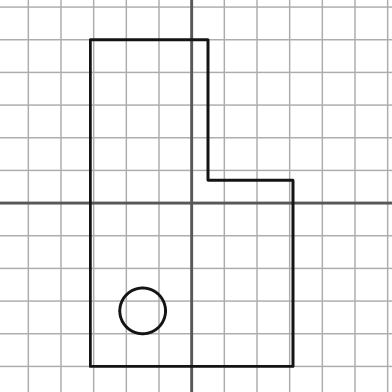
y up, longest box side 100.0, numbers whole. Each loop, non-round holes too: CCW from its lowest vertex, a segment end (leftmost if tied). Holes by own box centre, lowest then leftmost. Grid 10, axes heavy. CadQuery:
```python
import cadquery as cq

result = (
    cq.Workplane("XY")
    .moveTo(-31.0, -50.0)
    .lineTo(31.0, -50.0)
    .lineTo(31.0, 7.0)
    .lineTo(5.0, 7.0)
    .lineTo(5.0, 50.0)
    .lineTo(-31.0, 50.0)
    .close()
    .moveTo(-15.0, -33.0)
    .circle(7.0)
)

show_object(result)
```